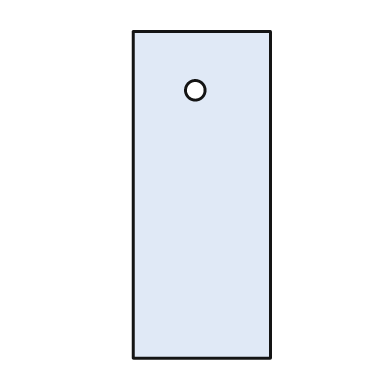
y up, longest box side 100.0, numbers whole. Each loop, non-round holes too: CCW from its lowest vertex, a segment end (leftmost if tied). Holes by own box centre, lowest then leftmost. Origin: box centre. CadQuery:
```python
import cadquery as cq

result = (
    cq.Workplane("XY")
    .moveTo(-21.0, -50.0)
    .lineTo(21.0, -50.0)
    .lineTo(21.0, 50.0)
    .lineTo(-21.0, 50.0)
    .close()
    .moveTo(-2.0, 32.0)
    .circle(3.0)
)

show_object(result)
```